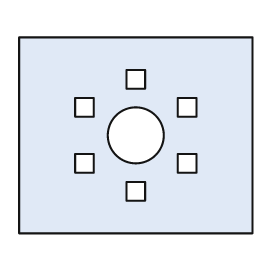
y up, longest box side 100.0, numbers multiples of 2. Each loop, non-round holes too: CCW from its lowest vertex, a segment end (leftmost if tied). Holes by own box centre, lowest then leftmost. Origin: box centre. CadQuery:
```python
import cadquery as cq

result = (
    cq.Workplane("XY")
    .moveTo(-50.0, -42.0)
    .lineTo(50.0, -42.0)
    .lineTo(50.0, 42.0)
    .lineTo(-50.0, 42.0)
    .close()
    .moveTo(-4.0, -28.0)
    .lineTo(4.0, -28.0)
    .lineTo(4.0, -20.0)
    .lineTo(-4.0, -20.0)
    .close()
    .moveTo(-26.0, -16.0)
    .lineTo(-18.0, -16.0)
    .lineTo(-18.0, -8.0)
    .lineTo(-26.0, -8.0)
    .close()
    .moveTo(18.0, -16.0)
    .lineTo(26.0, -16.0)
    .lineTo(26.0, -8.0)
    .lineTo(18.0, -8.0)
    .close()
    .moveTo(0.0, 0.0)
    .circle(12.0)
    .moveTo(-26.0, 8.0)
    .lineTo(-18.0, 8.0)
    .lineTo(-18.0, 16.0)
    .lineTo(-26.0, 16.0)
    .close()
    .moveTo(18.0, 8.0)
    .lineTo(26.0, 8.0)
    .lineTo(26.0, 16.0)
    .lineTo(18.0, 16.0)
    .close()
    .moveTo(-4.0, 20.0)
    .lineTo(4.0, 20.0)
    .lineTo(4.0, 28.0)
    .lineTo(-4.0, 28.0)
    .close()
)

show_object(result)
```